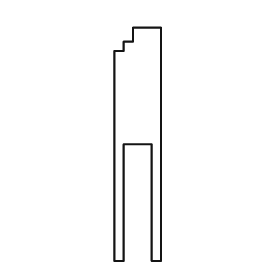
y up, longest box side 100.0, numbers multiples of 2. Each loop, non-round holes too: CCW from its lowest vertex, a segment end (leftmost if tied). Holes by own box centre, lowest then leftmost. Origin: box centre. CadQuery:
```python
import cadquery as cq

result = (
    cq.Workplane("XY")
    .moveTo(-10.0, -50.0)
    .lineTo(-6.0, -50.0)
    .lineTo(-6.0, 0.0)
    .lineTo(6.0, 0.0)
    .lineTo(6.0, -50.0)
    .lineTo(10.0, -50.0)
    .lineTo(10.0, 50.0)
    .lineTo(-2.0, 50.0)
    .lineTo(-2.0, 44.0)
    .lineTo(-6.0, 44.0)
    .lineTo(-6.0, 40.0)
    .lineTo(-10.0, 40.0)
    .close()
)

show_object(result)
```